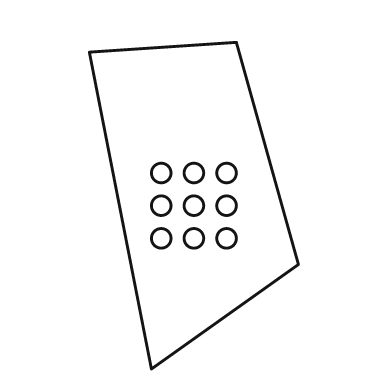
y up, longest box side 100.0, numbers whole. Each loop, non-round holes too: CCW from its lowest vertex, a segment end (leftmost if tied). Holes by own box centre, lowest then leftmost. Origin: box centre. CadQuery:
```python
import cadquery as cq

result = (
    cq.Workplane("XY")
    .moveTo(-13.0, -50.0)
    .lineTo(32.0, -18.0)
    .lineTo(13.0, 50.0)
    .lineTo(-32.0, 47.0)
    .close()
    .moveTo(-10.0, -10.0)
    .circle(3.0)
    .moveTo(0.0, -10.0)
    .circle(3.0)
    .moveTo(10.0, -10.0)
    .circle(3.0)
    .moveTo(-10.0, 0.0)
    .circle(3.0)
    .moveTo(0.0, 0.0)
    .circle(3.0)
    .moveTo(10.0, 0.0)
    .circle(3.0)
    .moveTo(-10.0, 10.0)
    .circle(3.0)
    .moveTo(0.0, 10.0)
    .circle(3.0)
    .moveTo(10.0, 10.0)
    .circle(3.0)
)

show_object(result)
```